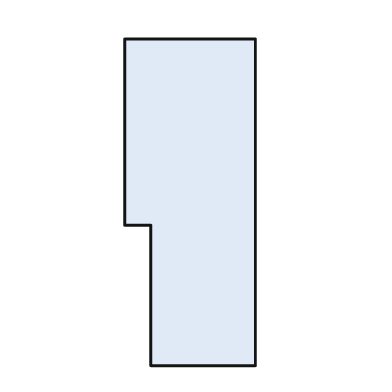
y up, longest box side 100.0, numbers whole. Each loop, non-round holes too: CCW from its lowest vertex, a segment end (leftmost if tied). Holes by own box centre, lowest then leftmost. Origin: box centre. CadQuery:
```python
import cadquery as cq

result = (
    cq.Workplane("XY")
    .moveTo(-12.0, -50.0)
    .lineTo(20.0, -50.0)
    .lineTo(20.0, 50.0)
    .lineTo(-20.0, 50.0)
    .lineTo(-20.0, -7.0)
    .lineTo(-12.0, -7.0)
    .close()
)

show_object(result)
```